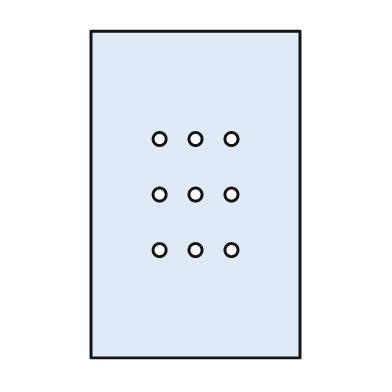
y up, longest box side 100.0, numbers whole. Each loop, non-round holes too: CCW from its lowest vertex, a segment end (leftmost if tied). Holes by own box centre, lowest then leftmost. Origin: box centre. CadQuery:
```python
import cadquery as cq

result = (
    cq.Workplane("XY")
    .moveTo(-32.0, -50.0)
    .lineTo(32.0, -50.0)
    .lineTo(32.0, 50.0)
    .lineTo(-32.0, 50.0)
    .close()
    .moveTo(-11.0, -17.0)
    .circle(2.0)
    .moveTo(0.0, -17.0)
    .circle(2.0)
    .moveTo(11.0, -17.0)
    .circle(2.0)
    .moveTo(-11.0, 0.0)
    .circle(2.0)
    .moveTo(0.0, 0.0)
    .circle(2.0)
    .moveTo(11.0, 0.0)
    .circle(2.0)
    .moveTo(-11.0, 17.0)
    .circle(2.0)
    .moveTo(0.0, 17.0)
    .circle(2.0)
    .moveTo(11.0, 17.0)
    .circle(2.0)
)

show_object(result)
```